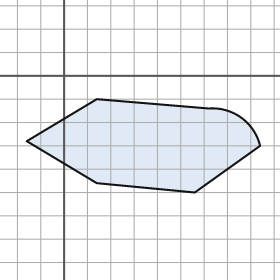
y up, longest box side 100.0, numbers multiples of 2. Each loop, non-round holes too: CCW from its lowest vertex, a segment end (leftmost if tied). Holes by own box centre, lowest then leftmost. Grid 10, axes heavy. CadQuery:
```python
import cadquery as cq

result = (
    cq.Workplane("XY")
    .moveTo(56.0, -50.0)
    .lineTo(84.0, -30.0)
    .threePointArc((76.0, -18.0), (62.0, -14.0))
    .lineTo(14.0, -10.0)
    .lineTo(-16.0, -28.0)
    .lineTo(14.0, -46.0)
    .close()
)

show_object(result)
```